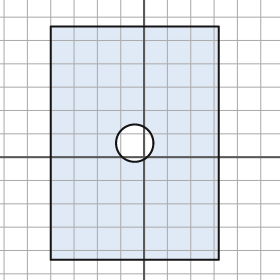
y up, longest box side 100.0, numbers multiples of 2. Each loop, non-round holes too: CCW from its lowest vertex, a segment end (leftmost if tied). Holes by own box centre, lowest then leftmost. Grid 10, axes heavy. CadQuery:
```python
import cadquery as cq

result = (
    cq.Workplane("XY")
    .moveTo(-40.0, -44.0)
    .lineTo(32.0, -44.0)
    .lineTo(32.0, 56.0)
    .lineTo(-40.0, 56.0)
    .close()
    .moveTo(-4.0, 6.0)
    .circle(8.0)
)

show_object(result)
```